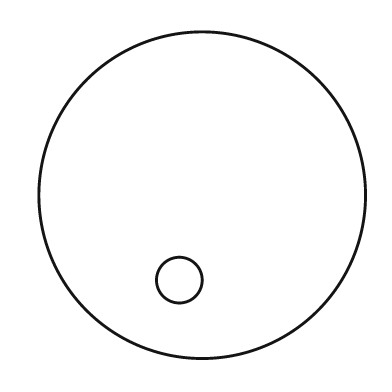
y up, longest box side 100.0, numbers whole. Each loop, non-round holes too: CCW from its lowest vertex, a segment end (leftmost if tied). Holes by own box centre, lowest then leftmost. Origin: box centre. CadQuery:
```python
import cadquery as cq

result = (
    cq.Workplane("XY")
    .moveTo(0.0, 0.0)
    .circle(50.0)
    .moveTo(-7.0, -26.0)
    .circle(7.0)
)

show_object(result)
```